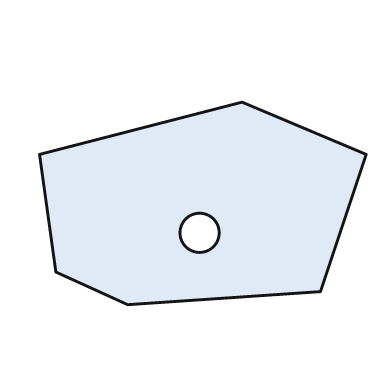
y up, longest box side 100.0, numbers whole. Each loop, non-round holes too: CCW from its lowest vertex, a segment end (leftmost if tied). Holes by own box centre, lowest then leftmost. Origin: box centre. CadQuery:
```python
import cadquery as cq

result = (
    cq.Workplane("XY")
    .moveTo(-23.0, -31.0)
    .lineTo(36.0, -27.0)
    .lineTo(50.0, 15.0)
    .lineTo(12.0, 31.0)
    .lineTo(-50.0, 15.0)
    .lineTo(-45.0, -21.0)
    .close()
    .moveTo(-1.0, -9.0)
    .circle(6.0)
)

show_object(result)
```